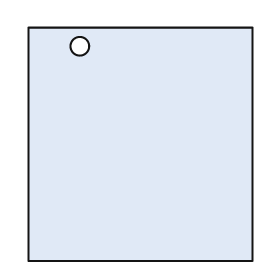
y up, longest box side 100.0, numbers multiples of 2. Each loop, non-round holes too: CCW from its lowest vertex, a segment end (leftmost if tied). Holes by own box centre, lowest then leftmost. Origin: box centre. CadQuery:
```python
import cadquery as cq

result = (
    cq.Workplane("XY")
    .moveTo(-48.0, -50.0)
    .lineTo(48.0, -50.0)
    .lineTo(48.0, 50.0)
    .lineTo(-48.0, 50.0)
    .close()
    .moveTo(-26.0, 42.0)
    .circle(4.0)
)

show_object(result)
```